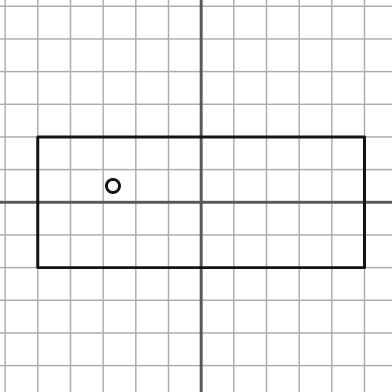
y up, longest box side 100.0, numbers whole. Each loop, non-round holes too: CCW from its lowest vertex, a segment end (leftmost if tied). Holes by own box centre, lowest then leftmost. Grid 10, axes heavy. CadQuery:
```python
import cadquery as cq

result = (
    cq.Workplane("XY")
    .moveTo(-50.0, -20.0)
    .lineTo(50.0, -20.0)
    .lineTo(50.0, 20.0)
    .lineTo(-50.0, 20.0)
    .close()
    .moveTo(-27.0, 5.0)
    .circle(2.0)
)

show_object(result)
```